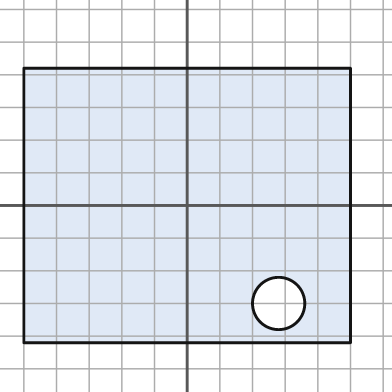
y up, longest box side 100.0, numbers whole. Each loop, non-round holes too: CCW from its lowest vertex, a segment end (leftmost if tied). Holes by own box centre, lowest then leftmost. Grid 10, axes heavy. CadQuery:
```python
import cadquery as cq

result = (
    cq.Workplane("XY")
    .moveTo(-50.0, -42.0)
    .lineTo(50.0, -42.0)
    .lineTo(50.0, 42.0)
    .lineTo(-50.0, 42.0)
    .close()
    .moveTo(28.0, -30.0)
    .circle(8.0)
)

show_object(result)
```